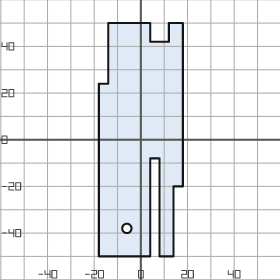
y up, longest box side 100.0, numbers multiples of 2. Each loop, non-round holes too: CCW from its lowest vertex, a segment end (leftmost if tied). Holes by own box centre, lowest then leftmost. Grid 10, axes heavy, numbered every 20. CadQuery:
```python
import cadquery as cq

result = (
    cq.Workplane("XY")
    .moveTo(-18.0, -50.0)
    .lineTo(4.0, -50.0)
    .lineTo(4.0, -8.0)
    .lineTo(8.0, -8.0)
    .lineTo(8.0, -50.0)
    .lineTo(14.0, -50.0)
    .lineTo(14.0, -20.0)
    .lineTo(18.0, -20.0)
    .lineTo(18.0, 50.0)
    .lineTo(12.0, 50.0)
    .lineTo(12.0, 42.0)
    .lineTo(4.0, 42.0)
    .lineTo(4.0, 50.0)
    .lineTo(-14.0, 50.0)
    .lineTo(-14.0, 24.0)
    .lineTo(-18.0, 24.0)
    .close()
    .moveTo(-6.0, -38.0)
    .circle(2.0)
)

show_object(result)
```